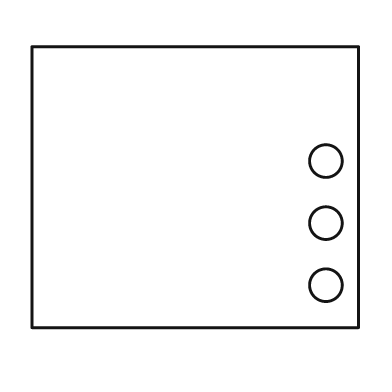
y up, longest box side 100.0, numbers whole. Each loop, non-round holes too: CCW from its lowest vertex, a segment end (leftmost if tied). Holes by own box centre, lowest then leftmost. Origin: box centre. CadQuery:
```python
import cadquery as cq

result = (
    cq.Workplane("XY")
    .moveTo(-50.0, -43.0)
    .lineTo(50.0, -43.0)
    .lineTo(50.0, 43.0)
    .lineTo(-50.0, 43.0)
    .close()
    .moveTo(40.0, -30.0)
    .circle(5.0)
    .moveTo(40.0, -11.0)
    .circle(5.0)
    .moveTo(40.0, 8.0)
    .circle(5.0)
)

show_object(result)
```